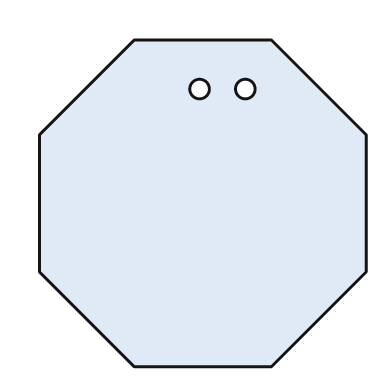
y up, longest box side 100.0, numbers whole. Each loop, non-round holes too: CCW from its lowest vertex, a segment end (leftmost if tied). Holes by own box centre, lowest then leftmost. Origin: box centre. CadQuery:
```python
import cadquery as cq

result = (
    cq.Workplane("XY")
    .moveTo(-21.0, -50.0)
    .lineTo(21.0, -50.0)
    .lineTo(50.0, -21.0)
    .lineTo(50.0, 21.0)
    .lineTo(21.0, 50.0)
    .lineTo(-21.0, 50.0)
    .lineTo(-50.0, 21.0)
    .lineTo(-50.0, -21.0)
    .close()
    .moveTo(-1.0, 35.0)
    .circle(3.0)
    .moveTo(13.0, 35.0)
    .circle(3.0)
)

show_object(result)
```